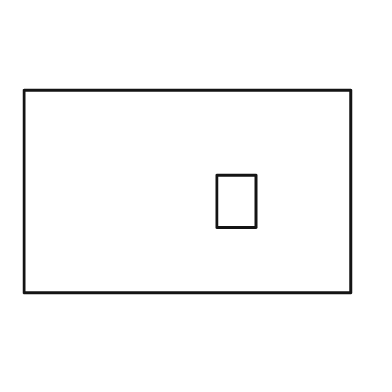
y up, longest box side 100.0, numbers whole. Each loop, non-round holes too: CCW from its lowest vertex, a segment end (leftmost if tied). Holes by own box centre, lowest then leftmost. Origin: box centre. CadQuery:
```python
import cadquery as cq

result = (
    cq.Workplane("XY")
    .moveTo(-50.0, -31.0)
    .lineTo(50.0, -31.0)
    .lineTo(50.0, 31.0)
    .lineTo(-50.0, 31.0)
    .close()
    .moveTo(9.0, -11.0)
    .lineTo(21.0, -11.0)
    .lineTo(21.0, 5.0)
    .lineTo(9.0, 5.0)
    .close()
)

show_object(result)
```